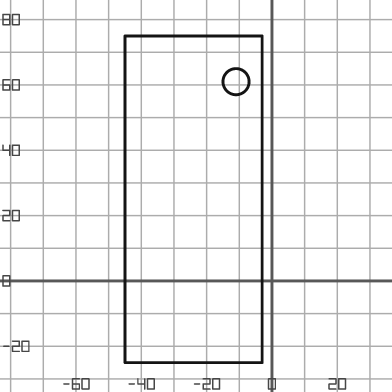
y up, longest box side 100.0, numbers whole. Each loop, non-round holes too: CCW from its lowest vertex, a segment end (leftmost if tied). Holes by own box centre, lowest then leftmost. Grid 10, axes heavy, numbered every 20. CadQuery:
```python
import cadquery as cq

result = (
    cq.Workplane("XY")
    .moveTo(-45.0, -25.0)
    .lineTo(-3.0, -25.0)
    .lineTo(-3.0, 75.0)
    .lineTo(-45.0, 75.0)
    .close()
    .moveTo(-11.0, 61.0)
    .circle(4.0)
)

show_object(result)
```